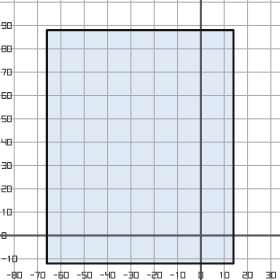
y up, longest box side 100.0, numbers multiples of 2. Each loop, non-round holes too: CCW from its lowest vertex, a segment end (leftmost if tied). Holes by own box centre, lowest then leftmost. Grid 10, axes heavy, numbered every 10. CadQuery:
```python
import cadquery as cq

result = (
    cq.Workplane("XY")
    .moveTo(-66.0, -12.0)
    .lineTo(14.0, -12.0)
    .lineTo(14.0, 88.0)
    .lineTo(-66.0, 88.0)
    .close()
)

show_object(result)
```